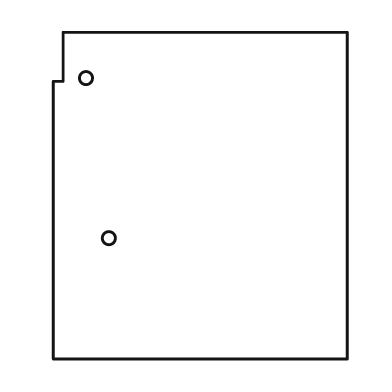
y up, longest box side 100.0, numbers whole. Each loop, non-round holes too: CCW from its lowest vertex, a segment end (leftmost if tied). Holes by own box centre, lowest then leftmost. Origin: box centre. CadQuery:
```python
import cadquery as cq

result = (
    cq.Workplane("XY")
    .moveTo(-45.0, -50.0)
    .lineTo(45.0, -50.0)
    .lineTo(45.0, 50.0)
    .lineTo(-42.0, 50.0)
    .lineTo(-42.0, 35.0)
    .lineTo(-45.0, 35.0)
    .close()
    .moveTo(-28.0, -13.0)
    .circle(2.0)
    .moveTo(-35.0, 36.0)
    .circle(2.0)
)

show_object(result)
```